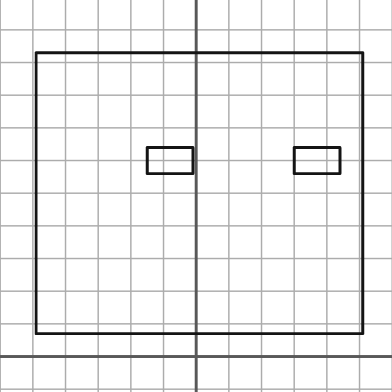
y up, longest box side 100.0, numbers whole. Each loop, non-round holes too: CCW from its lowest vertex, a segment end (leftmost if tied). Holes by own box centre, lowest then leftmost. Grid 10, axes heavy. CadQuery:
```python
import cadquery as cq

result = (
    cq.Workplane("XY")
    .moveTo(-49.0, 7.0)
    .lineTo(51.0, 7.0)
    .lineTo(51.0, 93.0)
    .lineTo(-49.0, 93.0)
    .close()
    .moveTo(-15.0, 56.0)
    .lineTo(-1.0, 56.0)
    .lineTo(-1.0, 64.0)
    .lineTo(-15.0, 64.0)
    .close()
    .moveTo(30.0, 56.0)
    .lineTo(44.0, 56.0)
    .lineTo(44.0, 64.0)
    .lineTo(30.0, 64.0)
    .close()
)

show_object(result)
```